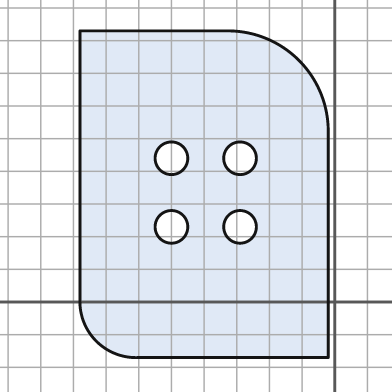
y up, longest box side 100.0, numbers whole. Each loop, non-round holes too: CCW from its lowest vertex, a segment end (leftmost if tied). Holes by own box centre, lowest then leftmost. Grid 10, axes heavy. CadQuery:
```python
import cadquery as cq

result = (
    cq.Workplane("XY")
    .moveTo(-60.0, -17.0)
    .lineTo(-2.0, -17.0)
    .lineTo(-2.0, 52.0)
    .threePointArc((-11.0, 74.0), (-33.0, 83.0))
    .lineTo(-78.0, 83.0)
    .lineTo(-78.0, 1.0)
    .threePointArc((-73.0, -12.0), (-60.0, -17.0))
    .close()
    .moveTo(-50.0, 23.0)
    .circle(5.0)
    .moveTo(-29.0, 23.0)
    .circle(5.0)
    .moveTo(-50.0, 44.0)
    .circle(5.0)
    .moveTo(-29.0, 44.0)
    .circle(5.0)
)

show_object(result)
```